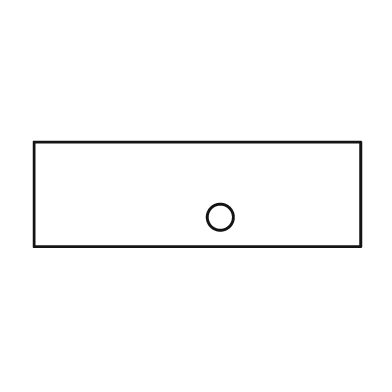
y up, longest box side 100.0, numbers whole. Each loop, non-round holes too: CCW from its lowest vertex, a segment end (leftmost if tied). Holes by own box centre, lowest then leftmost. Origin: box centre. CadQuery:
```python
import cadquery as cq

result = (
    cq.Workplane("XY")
    .moveTo(-50.0, -16.0)
    .lineTo(50.0, -16.0)
    .lineTo(50.0, 16.0)
    .lineTo(-50.0, 16.0)
    .close()
    .moveTo(7.0, -7.0)
    .circle(4.0)
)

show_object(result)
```